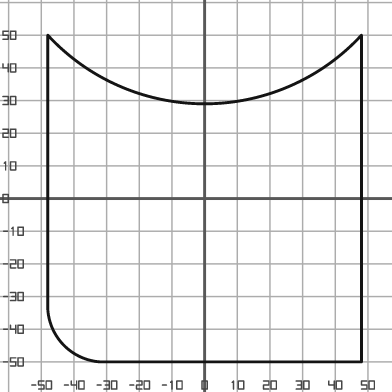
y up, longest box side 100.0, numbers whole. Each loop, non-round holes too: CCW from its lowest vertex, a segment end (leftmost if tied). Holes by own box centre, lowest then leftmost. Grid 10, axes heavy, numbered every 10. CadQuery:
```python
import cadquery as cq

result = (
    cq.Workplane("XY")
    .moveTo(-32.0, -50.0)
    .lineTo(48.0, -50.0)
    .lineTo(48.0, 50.0)
    .threePointArc((0.0, 29.0), (-48.0, 50.0))
    .lineTo(-48.0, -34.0)
    .threePointArc((-43.0, -45.0), (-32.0, -50.0))
    .close()
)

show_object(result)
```